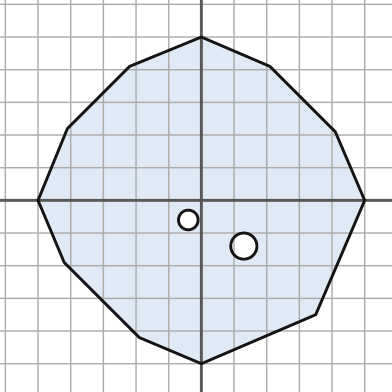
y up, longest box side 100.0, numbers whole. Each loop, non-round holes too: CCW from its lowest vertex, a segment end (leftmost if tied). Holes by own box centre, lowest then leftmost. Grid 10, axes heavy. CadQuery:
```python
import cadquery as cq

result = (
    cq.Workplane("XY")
    .moveTo(0.0, -50.0)
    .lineTo(35.0, -35.0)
    .lineTo(50.0, 0.0)
    .lineTo(41.0, 21.0)
    .lineTo(21.0, 41.0)
    .lineTo(0.0, 50.0)
    .lineTo(-22.0, 41.0)
    .lineTo(-41.0, 22.0)
    .lineTo(-50.0, 0.0)
    .lineTo(-42.0, -19.0)
    .lineTo(-19.0, -42.0)
    .close()
    .moveTo(13.0, -14.0)
    .circle(4.0)
    .moveTo(-4.0, -6.0)
    .circle(3.0)
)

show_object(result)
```